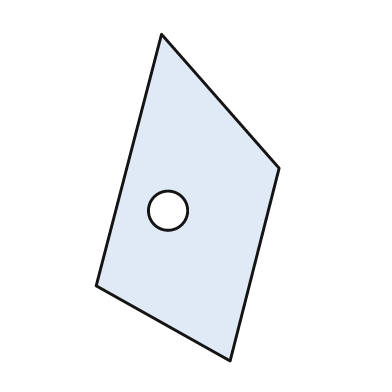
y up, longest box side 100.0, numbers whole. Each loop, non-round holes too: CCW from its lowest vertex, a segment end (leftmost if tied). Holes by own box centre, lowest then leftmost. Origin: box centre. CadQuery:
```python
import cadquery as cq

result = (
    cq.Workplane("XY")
    .moveTo(13.0, -50.0)
    .lineTo(28.0, 9.0)
    .lineTo(-8.0, 50.0)
    .lineTo(-28.0, -27.0)
    .close()
    .moveTo(-6.0, -4.0)
    .circle(6.0)
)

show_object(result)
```